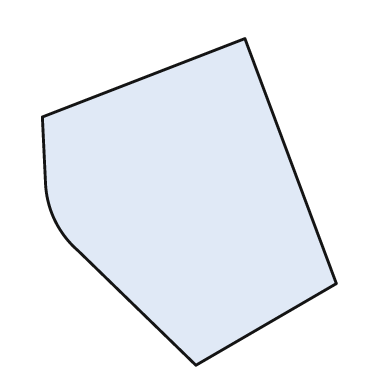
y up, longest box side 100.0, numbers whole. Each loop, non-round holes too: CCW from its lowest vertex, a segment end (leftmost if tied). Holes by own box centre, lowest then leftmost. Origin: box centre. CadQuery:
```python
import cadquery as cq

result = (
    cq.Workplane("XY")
    .moveTo(2.0, -50.0)
    .lineTo(45.0, -25.0)
    .lineTo(17.0, 50.0)
    .lineTo(-45.0, 26.0)
    .lineTo(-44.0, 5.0)
    .threePointArc((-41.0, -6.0), (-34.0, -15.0))
    .close()
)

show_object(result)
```